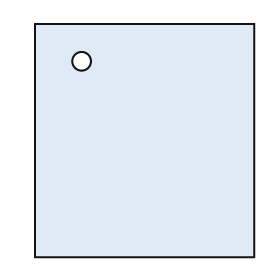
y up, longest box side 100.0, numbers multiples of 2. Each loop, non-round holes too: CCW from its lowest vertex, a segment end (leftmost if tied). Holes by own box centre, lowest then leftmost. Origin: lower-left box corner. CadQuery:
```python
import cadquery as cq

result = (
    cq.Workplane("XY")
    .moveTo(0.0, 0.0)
    .lineTo(94.0, 0.0)
    .lineTo(94.0, 100.0)
    .lineTo(0.0, 100.0)
    .close()
    .moveTo(20.0, 84.0)
    .circle(4.0)
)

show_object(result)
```